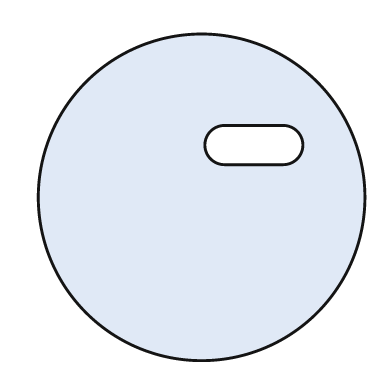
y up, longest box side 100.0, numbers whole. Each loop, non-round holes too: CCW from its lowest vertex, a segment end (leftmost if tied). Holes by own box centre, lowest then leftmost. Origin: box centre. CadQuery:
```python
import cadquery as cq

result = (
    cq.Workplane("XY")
    .moveTo(0.0, 0.0)
    .circle(50.0)
    .moveTo(7.0, 10.0)
    .lineTo(25.0, 10.0)
    .threePointArc((31.0, 16.0), (25.0, 22.0))
    .lineTo(7.0, 22.0)
    .threePointArc((1.0, 16.0), (7.0, 10.0))
    .close()
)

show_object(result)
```